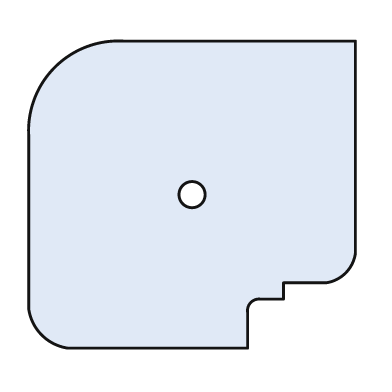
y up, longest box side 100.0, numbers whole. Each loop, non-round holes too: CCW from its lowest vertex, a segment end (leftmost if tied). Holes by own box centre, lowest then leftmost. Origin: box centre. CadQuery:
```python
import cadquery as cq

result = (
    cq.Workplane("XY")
    .moveTo(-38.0, -47.0)
    .lineTo(17.0, -47.0)
    .lineTo(17.0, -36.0)
    .threePointArc((18.0, -33.0), (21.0, -32.0))
    .lineTo(28.0, -32.0)
    .lineTo(28.0, -27.0)
    .lineTo(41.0, -27.0)
    .threePointArc((47.0, -24.0), (50.0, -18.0))
    .lineTo(50.0, 47.0)
    .lineTo(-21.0, 47.0)
    .threePointArc((-42.0, 39.0), (-50.0, 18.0))
    .lineTo(-50.0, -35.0)
    .threePointArc((-46.0, -43.0), (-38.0, -47.0))
    .close()
    .moveTo(0.0, 0.0)
    .circle(4.0)
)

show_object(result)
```